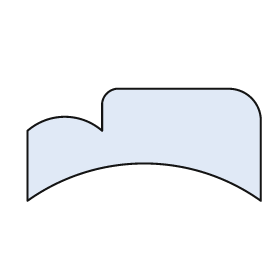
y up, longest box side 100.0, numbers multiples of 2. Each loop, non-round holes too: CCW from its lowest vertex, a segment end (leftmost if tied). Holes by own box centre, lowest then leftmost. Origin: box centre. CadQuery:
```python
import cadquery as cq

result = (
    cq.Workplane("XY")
    .moveTo(-50.0, -24.0)
    .threePointArc((0.0, -8.0), (50.0, -24.0))
    .lineTo(50.0, 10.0)
    .threePointArc((46.0, 20.0), (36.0, 24.0))
    .lineTo(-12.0, 24.0)
    .threePointArc((-16.0, 22.0), (-18.0, 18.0))
    .lineTo(-18.0, 6.0)
    .threePointArc((-34.0, 12.0), (-50.0, 6.0))
    .close()
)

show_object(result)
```